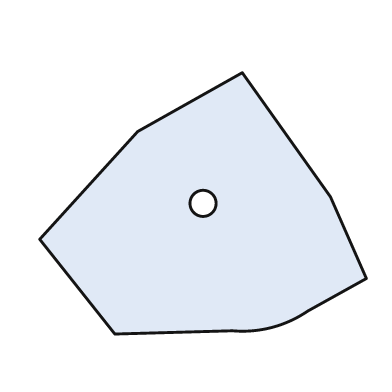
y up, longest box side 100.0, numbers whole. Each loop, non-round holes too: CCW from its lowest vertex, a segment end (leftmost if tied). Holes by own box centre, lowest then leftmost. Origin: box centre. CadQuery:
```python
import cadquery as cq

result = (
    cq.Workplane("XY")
    .moveTo(-27.0, -40.0)
    .lineTo(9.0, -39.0)
    .threePointArc((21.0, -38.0), (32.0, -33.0))
    .lineTo(50.0, -23.0)
    .lineTo(39.0, 2.0)
    .lineTo(12.0, 40.0)
    .lineTo(-20.0, 22.0)
    .lineTo(-50.0, -11.0)
    .close()
    .moveTo(0.0, 0.0)
    .circle(4.0)
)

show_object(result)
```